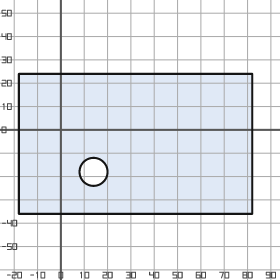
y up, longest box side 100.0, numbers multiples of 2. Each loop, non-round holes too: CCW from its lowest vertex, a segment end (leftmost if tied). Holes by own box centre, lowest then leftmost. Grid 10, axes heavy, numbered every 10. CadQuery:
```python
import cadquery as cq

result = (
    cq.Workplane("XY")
    .moveTo(-18.0, -36.0)
    .lineTo(82.0, -36.0)
    .lineTo(82.0, 24.0)
    .lineTo(-18.0, 24.0)
    .close()
    .moveTo(14.0, -18.0)
    .circle(6.0)
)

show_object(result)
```